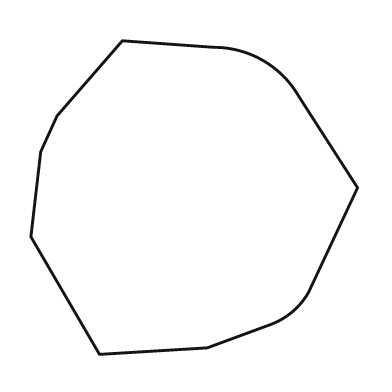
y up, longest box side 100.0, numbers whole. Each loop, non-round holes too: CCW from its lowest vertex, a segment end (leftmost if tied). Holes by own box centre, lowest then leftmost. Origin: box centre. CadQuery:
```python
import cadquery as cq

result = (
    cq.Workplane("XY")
    .moveTo(-29.0, -48.0)
    .lineTo(4.0, -46.0)
    .lineTo(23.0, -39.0)
    .threePointArc((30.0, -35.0), (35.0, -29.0))
    .lineTo(50.0, 3.0)
    .lineTo(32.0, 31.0)
    .threePointArc((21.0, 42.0), (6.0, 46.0))
    .lineTo(-22.0, 48.0)
    .lineTo(-42.0, 25.0)
    .lineTo(-47.0, 14.0)
    .lineTo(-50.0, -12.0)
    .close()
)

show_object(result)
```